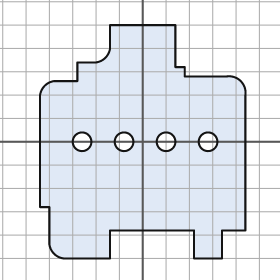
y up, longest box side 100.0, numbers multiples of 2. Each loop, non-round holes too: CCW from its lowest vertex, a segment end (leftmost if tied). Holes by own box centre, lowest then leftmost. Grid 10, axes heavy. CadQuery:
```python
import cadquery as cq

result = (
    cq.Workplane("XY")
    .moveTo(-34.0, -50.0)
    .lineTo(-14.0, -50.0)
    .lineTo(-14.0, -38.0)
    .lineTo(22.0, -38.0)
    .lineTo(22.0, -50.0)
    .lineTo(34.0, -50.0)
    .lineTo(34.0, -38.0)
    .lineTo(44.0, -38.0)
    .lineTo(44.0, 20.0)
    .threePointArc((42.0, 26.0), (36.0, 28.0))
    .lineTo(18.0, 28.0)
    .lineTo(18.0, 32.0)
    .lineTo(14.0, 32.0)
    .lineTo(14.0, 50.0)
    .lineTo(-14.0, 50.0)
    .lineTo(-14.0, 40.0)
    .threePointArc((-16.0, 36.0), (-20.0, 34.0))
    .lineTo(-28.0, 34.0)
    .lineTo(-28.0, 26.0)
    .lineTo(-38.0, 26.0)
    .threePointArc((-42.0, 24.0), (-44.0, 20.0))
    .lineTo(-44.0, -28.0)
    .lineTo(-40.0, -28.0)
    .lineTo(-40.0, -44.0)
    .threePointArc((-38.0, -48.0), (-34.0, -50.0))
    .close()
    .moveTo(-26.0, 0.0)
    .circle(4.0)
    .moveTo(-8.0, 0.0)
    .circle(4.0)
    .moveTo(10.0, 0.0)
    .circle(4.0)
    .moveTo(28.0, 0.0)
    .circle(4.0)
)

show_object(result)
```